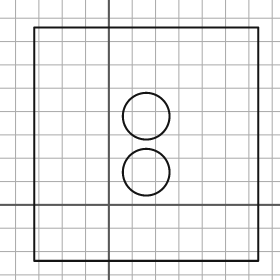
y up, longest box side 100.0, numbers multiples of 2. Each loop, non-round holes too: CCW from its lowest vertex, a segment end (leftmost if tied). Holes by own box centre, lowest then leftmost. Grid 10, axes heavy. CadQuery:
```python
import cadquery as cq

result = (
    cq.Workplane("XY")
    .moveTo(-32.0, -24.0)
    .lineTo(64.0, -24.0)
    .lineTo(64.0, 76.0)
    .lineTo(-32.0, 76.0)
    .close()
    .moveTo(16.0, 14.0)
    .circle(10.0)
    .moveTo(16.0, 38.0)
    .circle(10.0)
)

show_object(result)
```